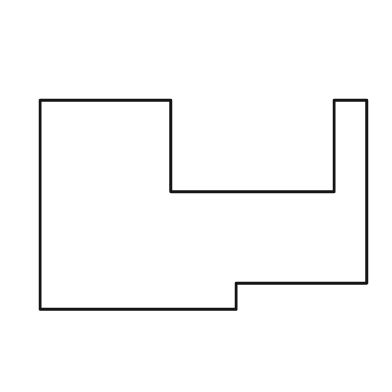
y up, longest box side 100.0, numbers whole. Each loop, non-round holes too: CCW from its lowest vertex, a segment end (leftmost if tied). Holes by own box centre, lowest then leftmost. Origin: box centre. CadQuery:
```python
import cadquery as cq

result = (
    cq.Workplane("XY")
    .moveTo(-50.0, -32.0)
    .lineTo(10.0, -32.0)
    .lineTo(10.0, -24.0)
    .lineTo(50.0, -24.0)
    .lineTo(50.0, 32.0)
    .lineTo(40.0, 32.0)
    .lineTo(40.0, 4.0)
    .lineTo(-10.0, 4.0)
    .lineTo(-10.0, 32.0)
    .lineTo(-50.0, 32.0)
    .close()
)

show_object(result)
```